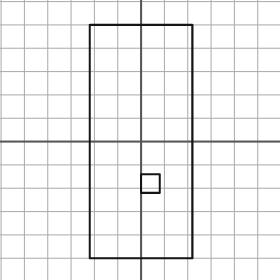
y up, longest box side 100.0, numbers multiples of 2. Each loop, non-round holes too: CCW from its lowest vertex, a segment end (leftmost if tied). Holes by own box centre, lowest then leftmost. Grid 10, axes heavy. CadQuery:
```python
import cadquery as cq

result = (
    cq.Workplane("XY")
    .moveTo(-22.0, -50.0)
    .lineTo(22.0, -50.0)
    .lineTo(22.0, 50.0)
    .lineTo(-22.0, 50.0)
    .close()
    .moveTo(0.0, -22.0)
    .lineTo(8.0, -22.0)
    .lineTo(8.0, -14.0)
    .lineTo(0.0, -14.0)
    .close()
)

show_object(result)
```